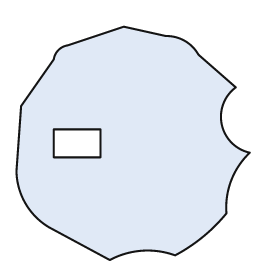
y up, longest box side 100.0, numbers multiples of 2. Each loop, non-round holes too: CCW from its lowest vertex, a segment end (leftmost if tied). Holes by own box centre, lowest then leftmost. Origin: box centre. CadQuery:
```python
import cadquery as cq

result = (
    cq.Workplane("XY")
    .moveTo(-10.0, -50.0)
    .threePointArc((4.0, -46.0), (18.0, -48.0))
    .threePointArc((30.0, -40.0), (40.0, -30.0))
    .threePointArc((42.0, -16.0), (50.0, -4.0))
    .threePointArc((38.0, 8.0), (44.0, 24.0))
    .lineTo(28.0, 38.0)
    .threePointArc((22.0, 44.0), (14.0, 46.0))
    .lineTo(-4.0, 50.0)
    .lineTo(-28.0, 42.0)
    .threePointArc((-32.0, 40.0), (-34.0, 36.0))
    .lineTo(-48.0, 16.0)
    .lineTo(-50.0, -12.0)
    .threePointArc((-46.0, -26.0), (-36.0, -36.0))
    .close()
    .moveTo(-34.0, -6.0)
    .lineTo(-14.0, -6.0)
    .lineTo(-14.0, 6.0)
    .lineTo(-34.0, 6.0)
    .close()
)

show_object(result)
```